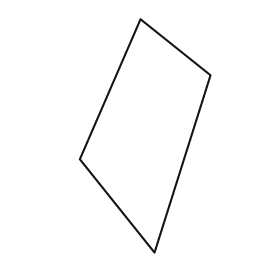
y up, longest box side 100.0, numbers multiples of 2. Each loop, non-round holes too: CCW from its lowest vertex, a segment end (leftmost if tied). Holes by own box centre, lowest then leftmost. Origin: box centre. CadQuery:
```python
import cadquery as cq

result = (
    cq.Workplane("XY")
    .moveTo(4.0, -50.0)
    .lineTo(28.0, 26.0)
    .lineTo(-2.0, 50.0)
    .lineTo(-28.0, -10.0)
    .close()
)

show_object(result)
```